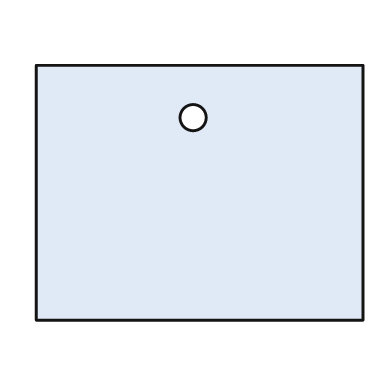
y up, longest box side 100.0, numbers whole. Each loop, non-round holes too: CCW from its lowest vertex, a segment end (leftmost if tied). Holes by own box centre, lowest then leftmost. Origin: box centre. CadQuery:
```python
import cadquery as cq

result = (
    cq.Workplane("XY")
    .moveTo(-50.0, -39.0)
    .lineTo(50.0, -39.0)
    .lineTo(50.0, 39.0)
    .lineTo(-50.0, 39.0)
    .close()
    .moveTo(-2.0, 23.0)
    .circle(4.0)
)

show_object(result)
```